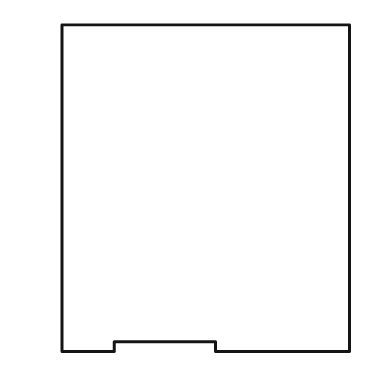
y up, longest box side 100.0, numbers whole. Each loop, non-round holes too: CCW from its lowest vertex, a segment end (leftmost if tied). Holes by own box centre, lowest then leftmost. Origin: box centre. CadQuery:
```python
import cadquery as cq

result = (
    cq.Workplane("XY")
    .moveTo(-44.0, -50.0)
    .lineTo(-28.0, -50.0)
    .lineTo(-28.0, -47.0)
    .lineTo(3.0, -47.0)
    .lineTo(3.0, -50.0)
    .lineTo(44.0, -50.0)
    .lineTo(44.0, 50.0)
    .lineTo(-44.0, 50.0)
    .close()
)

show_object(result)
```